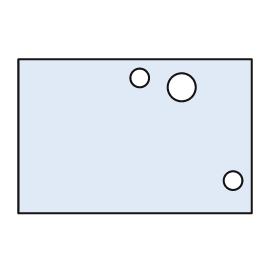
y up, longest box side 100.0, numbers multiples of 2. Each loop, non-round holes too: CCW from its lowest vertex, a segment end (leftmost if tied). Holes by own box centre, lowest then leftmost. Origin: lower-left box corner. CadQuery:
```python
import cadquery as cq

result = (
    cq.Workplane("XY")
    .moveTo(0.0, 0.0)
    .lineTo(100.0, 0.0)
    .lineTo(100.0, 66.0)
    .lineTo(0.0, 66.0)
    .close()
    .moveTo(92.0, 14.0)
    .circle(4.0)
    .moveTo(70.0, 54.0)
    .circle(6.0)
    .moveTo(52.0, 58.0)
    .circle(4.0)
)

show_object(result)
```